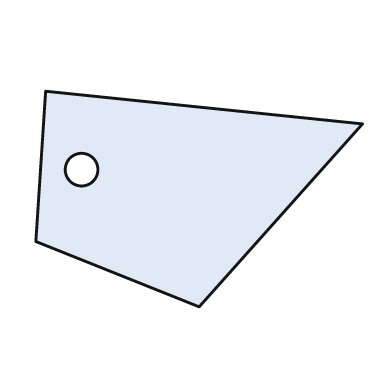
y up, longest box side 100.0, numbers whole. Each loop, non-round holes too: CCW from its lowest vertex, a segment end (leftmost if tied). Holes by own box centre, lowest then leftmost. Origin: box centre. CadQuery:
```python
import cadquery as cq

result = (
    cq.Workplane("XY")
    .moveTo(0.0, -33.0)
    .lineTo(50.0, 23.0)
    .lineTo(-47.0, 33.0)
    .lineTo(-50.0, -13.0)
    .close()
    .moveTo(-36.0, 9.0)
    .circle(5.0)
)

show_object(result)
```